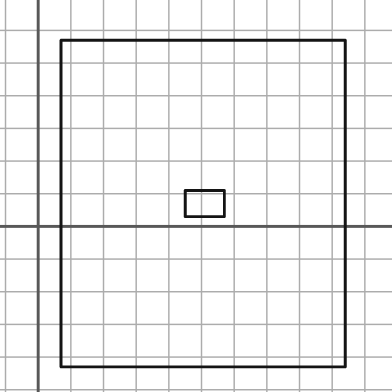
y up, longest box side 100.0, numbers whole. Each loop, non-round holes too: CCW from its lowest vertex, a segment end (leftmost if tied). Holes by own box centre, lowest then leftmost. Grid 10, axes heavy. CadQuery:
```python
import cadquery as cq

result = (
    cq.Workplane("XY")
    .moveTo(7.0, -43.0)
    .lineTo(94.0, -43.0)
    .lineTo(94.0, 57.0)
    .lineTo(7.0, 57.0)
    .close()
    .moveTo(45.0, 3.0)
    .lineTo(57.0, 3.0)
    .lineTo(57.0, 11.0)
    .lineTo(45.0, 11.0)
    .close()
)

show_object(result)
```